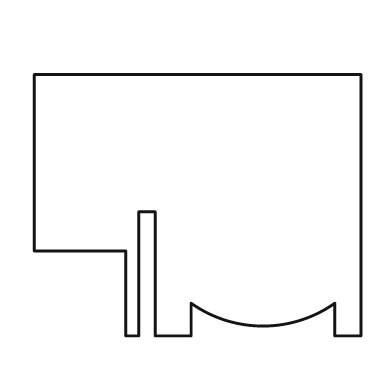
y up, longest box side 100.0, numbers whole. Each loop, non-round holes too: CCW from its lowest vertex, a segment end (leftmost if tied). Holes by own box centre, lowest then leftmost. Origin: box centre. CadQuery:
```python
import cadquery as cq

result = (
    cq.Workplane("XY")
    .moveTo(-22.0, -40.0)
    .lineTo(-18.0, -40.0)
    .lineTo(-18.0, -2.0)
    .lineTo(-13.0, -2.0)
    .lineTo(-13.0, -40.0)
    .lineTo(-2.0, -40.0)
    .lineTo(-2.0, -30.0)
    .threePointArc((20.0, -37.0), (42.0, -30.0))
    .lineTo(42.0, -40.0)
    .lineTo(50.0, -40.0)
    .lineTo(50.0, 40.0)
    .lineTo(-50.0, 40.0)
    .lineTo(-50.0, -14.0)
    .lineTo(-22.0, -14.0)
    .close()
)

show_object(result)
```